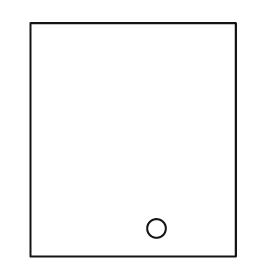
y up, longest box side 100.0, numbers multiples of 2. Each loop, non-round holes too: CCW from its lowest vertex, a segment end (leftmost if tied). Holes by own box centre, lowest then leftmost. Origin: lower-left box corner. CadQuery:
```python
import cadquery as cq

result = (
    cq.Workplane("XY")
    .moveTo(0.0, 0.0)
    .lineTo(88.0, 0.0)
    .lineTo(88.0, 100.0)
    .lineTo(0.0, 100.0)
    .close()
    .moveTo(54.0, 12.0)
    .circle(4.0)
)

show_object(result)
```